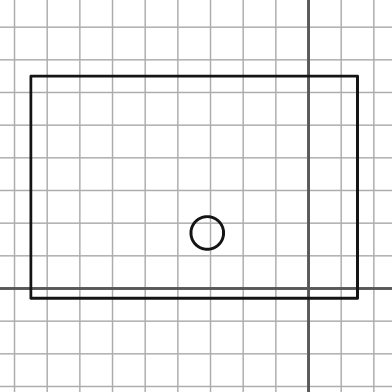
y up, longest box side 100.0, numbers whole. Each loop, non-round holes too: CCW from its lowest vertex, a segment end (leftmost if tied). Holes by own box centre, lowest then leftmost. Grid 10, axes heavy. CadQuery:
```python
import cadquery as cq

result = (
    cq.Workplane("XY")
    .moveTo(-85.0, -3.0)
    .lineTo(15.0, -3.0)
    .lineTo(15.0, 65.0)
    .lineTo(-85.0, 65.0)
    .close()
    .moveTo(-31.0, 17.0)
    .circle(5.0)
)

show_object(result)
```